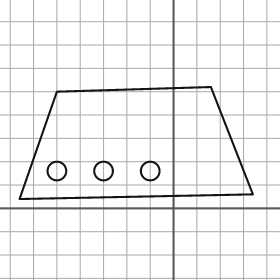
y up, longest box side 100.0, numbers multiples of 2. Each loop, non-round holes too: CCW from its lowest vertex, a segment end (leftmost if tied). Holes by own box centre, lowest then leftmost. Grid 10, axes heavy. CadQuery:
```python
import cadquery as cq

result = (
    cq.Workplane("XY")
    .moveTo(-66.0, 4.0)
    .lineTo(34.0, 6.0)
    .lineTo(16.0, 52.0)
    .lineTo(-50.0, 50.0)
    .close()
    .moveTo(-50.0, 16.0)
    .circle(4.0)
    .moveTo(-30.0, 16.0)
    .circle(4.0)
    .moveTo(-10.0, 16.0)
    .circle(4.0)
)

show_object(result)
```